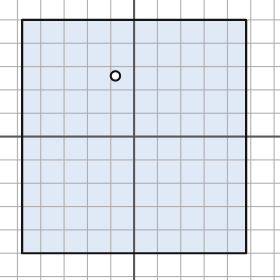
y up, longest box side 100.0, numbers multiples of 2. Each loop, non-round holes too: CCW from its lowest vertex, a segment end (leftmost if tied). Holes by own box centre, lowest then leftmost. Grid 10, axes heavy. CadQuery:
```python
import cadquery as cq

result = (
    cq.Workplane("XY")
    .moveTo(-48.0, -50.0)
    .lineTo(48.0, -50.0)
    .lineTo(48.0, 50.0)
    .lineTo(-48.0, 50.0)
    .close()
    .moveTo(-8.0, 26.0)
    .circle(2.0)
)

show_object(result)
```